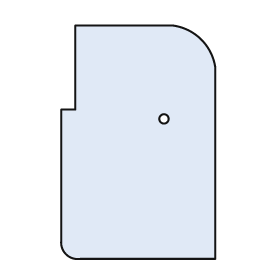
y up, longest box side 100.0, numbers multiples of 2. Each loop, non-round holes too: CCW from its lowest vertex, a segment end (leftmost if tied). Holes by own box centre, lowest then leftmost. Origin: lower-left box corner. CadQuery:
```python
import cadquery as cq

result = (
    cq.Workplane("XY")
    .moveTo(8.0, 0.0)
    .lineTo(66.0, 0.0)
    .lineTo(66.0, 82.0)
    .threePointArc((60.0, 94.0), (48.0, 100.0))
    .lineTo(6.0, 100.0)
    .lineTo(6.0, 64.0)
    .lineTo(0.0, 64.0)
    .lineTo(0.0, 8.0)
    .threePointArc((2.0, 2.0), (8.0, 0.0))
    .close()
    .moveTo(44.0, 60.0)
    .circle(2.0)
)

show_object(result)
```